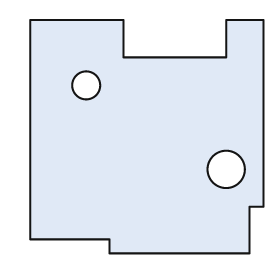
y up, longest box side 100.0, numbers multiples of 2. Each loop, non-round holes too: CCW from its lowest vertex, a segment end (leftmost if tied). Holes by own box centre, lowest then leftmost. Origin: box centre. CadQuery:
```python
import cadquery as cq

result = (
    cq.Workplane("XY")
    .moveTo(-16.0, -50.0)
    .lineTo(44.0, -50.0)
    .lineTo(44.0, -30.0)
    .lineTo(50.0, -30.0)
    .lineTo(50.0, 50.0)
    .lineTo(34.0, 50.0)
    .lineTo(34.0, 34.0)
    .lineTo(-10.0, 34.0)
    .lineTo(-10.0, 50.0)
    .lineTo(-50.0, 50.0)
    .lineTo(-50.0, -44.0)
    .lineTo(-16.0, -44.0)
    .close()
    .moveTo(34.0, -14.0)
    .circle(8.0)
    .moveTo(-26.0, 22.0)
    .circle(6.0)
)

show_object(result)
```